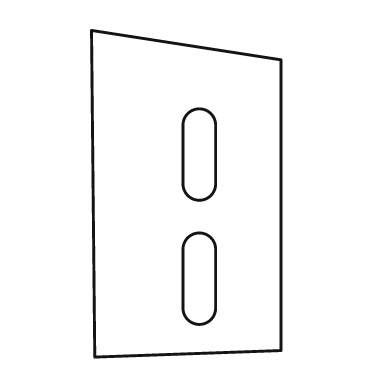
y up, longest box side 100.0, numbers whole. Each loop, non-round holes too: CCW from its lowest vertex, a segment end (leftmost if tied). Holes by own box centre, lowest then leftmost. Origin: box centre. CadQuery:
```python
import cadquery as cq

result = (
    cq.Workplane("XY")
    .moveTo(-28.0, -50.0)
    .lineTo(29.0, -48.0)
    .lineTo(29.0, 41.0)
    .lineTo(-29.0, 50.0)
    .close()
    .moveTo(-1.0, -35.0)
    .threePointArc((4.0, -40.0), (9.0, -35.0))
    .lineTo(9.0, -17.0)
    .threePointArc((4.0, -12.0), (-1.0, -17.0))
    .close()
    .moveTo(-1.0, 3.0)
    .threePointArc((4.0, -2.0), (9.0, 3.0))
    .lineTo(9.0, 21.0)
    .threePointArc((4.0, 26.0), (-1.0, 21.0))
    .close()
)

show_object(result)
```